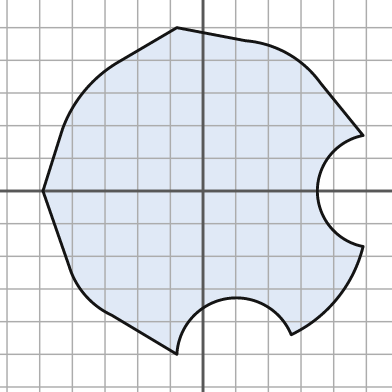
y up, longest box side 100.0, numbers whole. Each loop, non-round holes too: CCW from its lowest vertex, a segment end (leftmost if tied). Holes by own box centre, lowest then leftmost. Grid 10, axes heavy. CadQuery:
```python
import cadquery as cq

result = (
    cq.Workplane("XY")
    .moveTo(-8.0, -50.0)
    .threePointArc((7.0, -33.0), (27.0, -44.0))
    .threePointArc((41.0, -33.0), (49.0, -17.0))
    .threePointArc((35.0, 0.0), (49.0, 17.0))
    .lineTo(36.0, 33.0)
    .threePointArc((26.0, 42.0), (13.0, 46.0))
    .lineTo(-8.0, 50.0)
    .lineTo(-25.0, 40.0)
    .threePointArc((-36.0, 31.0), (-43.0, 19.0))
    .lineTo(-49.0, 0.0)
    .lineTo(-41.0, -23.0)
    .threePointArc((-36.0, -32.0), (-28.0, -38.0))
    .close()
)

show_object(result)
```